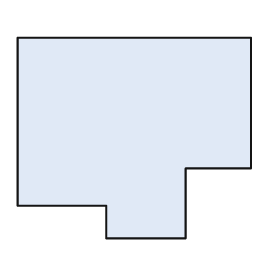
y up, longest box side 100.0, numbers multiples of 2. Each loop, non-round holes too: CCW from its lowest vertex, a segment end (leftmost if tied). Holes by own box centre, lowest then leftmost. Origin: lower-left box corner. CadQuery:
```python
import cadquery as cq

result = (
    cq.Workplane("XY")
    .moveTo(38.0, 0.0)
    .lineTo(72.0, 0.0)
    .lineTo(72.0, 30.0)
    .lineTo(100.0, 30.0)
    .lineTo(100.0, 86.0)
    .lineTo(0.0, 86.0)
    .lineTo(0.0, 14.0)
    .lineTo(38.0, 14.0)
    .close()
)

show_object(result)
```